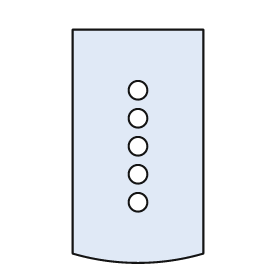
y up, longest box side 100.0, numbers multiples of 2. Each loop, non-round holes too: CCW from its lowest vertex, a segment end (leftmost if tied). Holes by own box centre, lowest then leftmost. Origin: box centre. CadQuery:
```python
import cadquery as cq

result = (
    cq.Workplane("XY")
    .moveTo(-28.0, -46.0)
    .threePointArc((0.0, -50.0), (28.0, -46.0))
    .lineTo(28.0, 50.0)
    .lineTo(-28.0, 50.0)
    .close()
    .moveTo(0.0, -24.0)
    .circle(4.0)
    .moveTo(0.0, -12.0)
    .circle(4.0)
    .moveTo(0.0, 0.0)
    .circle(4.0)
    .moveTo(0.0, 12.0)
    .circle(4.0)
    .moveTo(0.0, 24.0)
    .circle(4.0)
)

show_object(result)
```